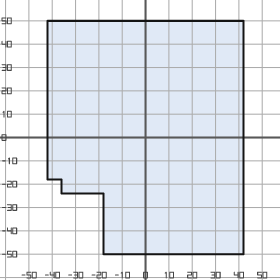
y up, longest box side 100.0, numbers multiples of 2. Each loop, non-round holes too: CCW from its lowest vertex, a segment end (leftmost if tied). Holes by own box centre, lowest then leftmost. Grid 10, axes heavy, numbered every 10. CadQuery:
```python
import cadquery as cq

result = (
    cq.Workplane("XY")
    .moveTo(-18.0, -50.0)
    .lineTo(42.0, -50.0)
    .lineTo(42.0, 50.0)
    .lineTo(-42.0, 50.0)
    .lineTo(-42.0, -18.0)
    .lineTo(-36.0, -18.0)
    .lineTo(-36.0, -24.0)
    .lineTo(-18.0, -24.0)
    .close()
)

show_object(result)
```